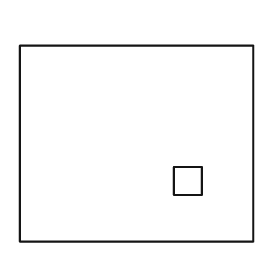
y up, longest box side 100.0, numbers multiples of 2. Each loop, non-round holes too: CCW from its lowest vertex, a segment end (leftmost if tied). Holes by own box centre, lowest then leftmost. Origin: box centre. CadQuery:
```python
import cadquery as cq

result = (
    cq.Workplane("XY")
    .moveTo(-50.0, -42.0)
    .lineTo(50.0, -42.0)
    .lineTo(50.0, 42.0)
    .lineTo(-50.0, 42.0)
    .close()
    .moveTo(16.0, -22.0)
    .lineTo(28.0, -22.0)
    .lineTo(28.0, -10.0)
    .lineTo(16.0, -10.0)
    .close()
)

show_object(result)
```